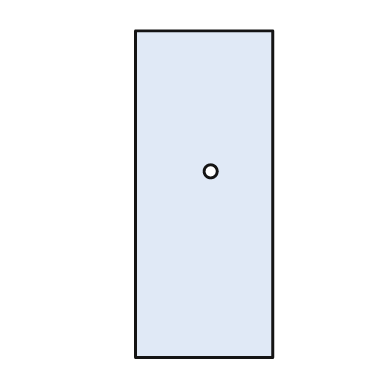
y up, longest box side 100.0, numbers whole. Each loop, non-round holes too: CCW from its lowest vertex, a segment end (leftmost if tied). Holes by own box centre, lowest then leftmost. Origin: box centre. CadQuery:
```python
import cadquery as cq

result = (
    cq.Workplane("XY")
    .moveTo(-21.0, -50.0)
    .lineTo(21.0, -50.0)
    .lineTo(21.0, 50.0)
    .lineTo(-21.0, 50.0)
    .close()
    .moveTo(2.0, 7.0)
    .circle(2.0)
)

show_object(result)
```